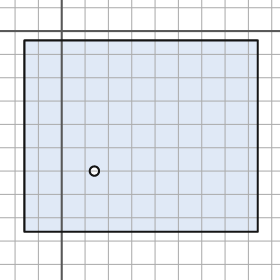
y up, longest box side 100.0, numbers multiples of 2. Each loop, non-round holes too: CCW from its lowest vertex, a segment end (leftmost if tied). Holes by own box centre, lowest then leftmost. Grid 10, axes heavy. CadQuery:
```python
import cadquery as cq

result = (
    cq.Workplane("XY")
    .moveTo(-16.0, -86.0)
    .lineTo(84.0, -86.0)
    .lineTo(84.0, -4.0)
    .lineTo(-16.0, -4.0)
    .close()
    .moveTo(14.0, -60.0)
    .circle(2.0)
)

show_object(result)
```